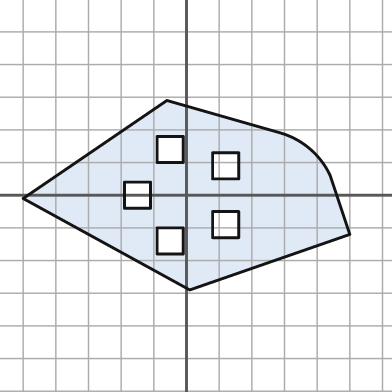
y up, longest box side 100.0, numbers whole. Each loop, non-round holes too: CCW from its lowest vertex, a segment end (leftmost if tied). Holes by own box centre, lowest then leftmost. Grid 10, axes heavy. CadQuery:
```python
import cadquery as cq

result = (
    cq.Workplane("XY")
    .moveTo(1.0, -29.0)
    .lineTo(50.0, -12.0)
    .lineTo(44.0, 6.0)
    .threePointArc((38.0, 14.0), (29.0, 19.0))
    .lineTo(-6.0, 29.0)
    .lineTo(-50.0, -1.0)
    .close()
    .moveTo(-9.0, -18.0)
    .lineTo(-1.0, -18.0)
    .lineTo(-1.0, -10.0)
    .lineTo(-9.0, -10.0)
    .close()
    .moveTo(8.0, -13.0)
    .lineTo(16.0, -13.0)
    .lineTo(16.0, -5.0)
    .lineTo(8.0, -5.0)
    .close()
    .moveTo(-19.0, -4.0)
    .lineTo(-11.0, -4.0)
    .lineTo(-11.0, 4.0)
    .lineTo(-19.0, 4.0)
    .close()
    .moveTo(8.0, 5.0)
    .lineTo(16.0, 5.0)
    .lineTo(16.0, 13.0)
    .lineTo(8.0, 13.0)
    .close()
    .moveTo(-9.0, 10.0)
    .lineTo(-1.0, 10.0)
    .lineTo(-1.0, 18.0)
    .lineTo(-9.0, 18.0)
    .close()
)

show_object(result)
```